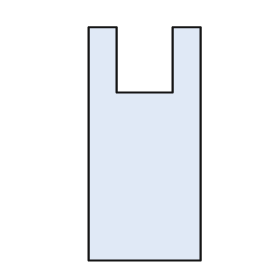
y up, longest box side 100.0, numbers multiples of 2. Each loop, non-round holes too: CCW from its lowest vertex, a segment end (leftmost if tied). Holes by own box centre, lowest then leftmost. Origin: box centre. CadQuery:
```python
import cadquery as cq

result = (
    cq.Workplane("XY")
    .moveTo(-24.0, -50.0)
    .lineTo(24.0, -50.0)
    .lineTo(24.0, 50.0)
    .lineTo(12.0, 50.0)
    .lineTo(12.0, 22.0)
    .lineTo(-12.0, 22.0)
    .lineTo(-12.0, 50.0)
    .lineTo(-24.0, 50.0)
    .close()
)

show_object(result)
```